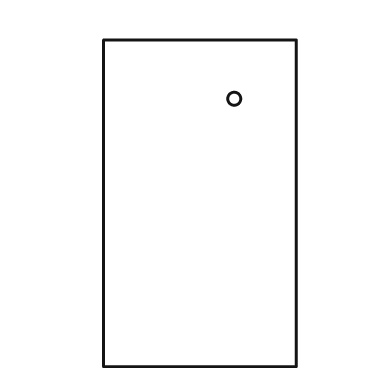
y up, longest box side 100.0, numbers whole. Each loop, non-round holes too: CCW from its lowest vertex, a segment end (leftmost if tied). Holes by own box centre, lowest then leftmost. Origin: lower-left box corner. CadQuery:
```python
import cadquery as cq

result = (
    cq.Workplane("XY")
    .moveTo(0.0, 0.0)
    .lineTo(59.0, 0.0)
    .lineTo(59.0, 100.0)
    .lineTo(0.0, 100.0)
    .close()
    .moveTo(40.0, 82.0)
    .circle(2.0)
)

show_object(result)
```